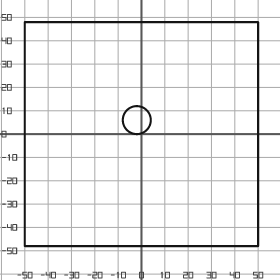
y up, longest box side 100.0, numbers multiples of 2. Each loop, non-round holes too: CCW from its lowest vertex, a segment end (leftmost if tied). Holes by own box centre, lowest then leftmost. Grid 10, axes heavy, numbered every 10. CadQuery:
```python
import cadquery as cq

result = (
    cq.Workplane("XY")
    .moveTo(-50.0, -48.0)
    .lineTo(50.0, -48.0)
    .lineTo(50.0, 48.0)
    .lineTo(-50.0, 48.0)
    .close()
    .moveTo(-2.0, 6.0)
    .circle(6.0)
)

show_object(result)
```